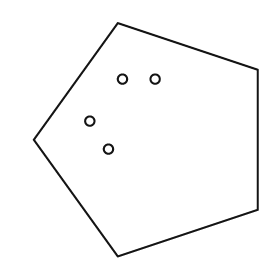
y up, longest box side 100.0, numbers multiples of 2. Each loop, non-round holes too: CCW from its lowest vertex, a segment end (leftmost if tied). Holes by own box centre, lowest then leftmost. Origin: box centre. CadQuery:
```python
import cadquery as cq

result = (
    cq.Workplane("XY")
    .moveTo(-12.0, -50.0)
    .lineTo(48.0, -30.0)
    .lineTo(48.0, 30.0)
    .lineTo(-12.0, 50.0)
    .lineTo(-48.0, 0.0)
    .close()
    .moveTo(-16.0, -4.0)
    .circle(2.0)
    .moveTo(-24.0, 8.0)
    .circle(2.0)
    .moveTo(-10.0, 26.0)
    .circle(2.0)
    .moveTo(4.0, 26.0)
    .circle(2.0)
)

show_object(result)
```